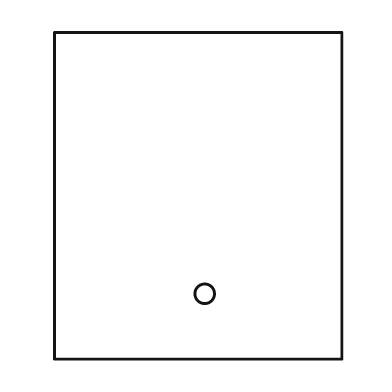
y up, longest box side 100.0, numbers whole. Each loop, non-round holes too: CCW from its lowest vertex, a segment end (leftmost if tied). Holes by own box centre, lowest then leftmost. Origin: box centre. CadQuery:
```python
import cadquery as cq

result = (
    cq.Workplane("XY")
    .moveTo(-44.0, -50.0)
    .lineTo(44.0, -50.0)
    .lineTo(44.0, 50.0)
    .lineTo(-44.0, 50.0)
    .close()
    .moveTo(2.0, -30.0)
    .circle(3.0)
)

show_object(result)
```